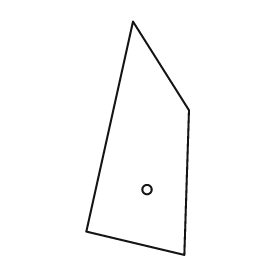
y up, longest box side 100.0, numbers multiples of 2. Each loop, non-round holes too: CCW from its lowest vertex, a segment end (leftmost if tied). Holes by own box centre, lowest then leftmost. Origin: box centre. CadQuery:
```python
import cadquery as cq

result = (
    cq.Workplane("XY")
    .moveTo(20.0, -50.0)
    .lineTo(22.0, 12.0)
    .lineTo(-2.0, 50.0)
    .lineTo(-22.0, -40.0)
    .close()
    .moveTo(4.0, -22.0)
    .circle(2.0)
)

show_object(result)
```